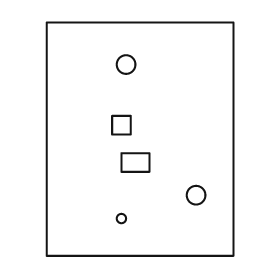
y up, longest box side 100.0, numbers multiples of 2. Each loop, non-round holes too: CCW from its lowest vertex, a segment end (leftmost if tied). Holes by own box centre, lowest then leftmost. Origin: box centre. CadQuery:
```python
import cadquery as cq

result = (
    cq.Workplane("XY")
    .moveTo(-40.0, -50.0)
    .lineTo(40.0, -50.0)
    .lineTo(40.0, 50.0)
    .lineTo(-40.0, 50.0)
    .close()
    .moveTo(-8.0, -34.0)
    .circle(2.0)
    .moveTo(24.0, -24.0)
    .circle(4.0)
    .moveTo(-8.0, -14.0)
    .lineTo(4.0, -14.0)
    .lineTo(4.0, -6.0)
    .lineTo(-8.0, -6.0)
    .close()
    .moveTo(-12.0, 2.0)
    .lineTo(-4.0, 2.0)
    .lineTo(-4.0, 10.0)
    .lineTo(-12.0, 10.0)
    .close()
    .moveTo(-6.0, 32.0)
    .circle(4.0)
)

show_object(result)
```